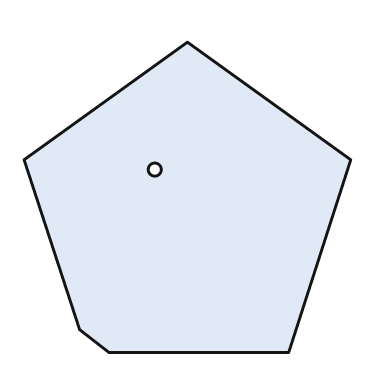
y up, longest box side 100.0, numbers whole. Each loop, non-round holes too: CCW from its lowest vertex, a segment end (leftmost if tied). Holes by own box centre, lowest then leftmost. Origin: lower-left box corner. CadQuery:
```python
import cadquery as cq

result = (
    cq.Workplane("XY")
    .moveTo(26.0, 0.0)
    .lineTo(81.0, 0.0)
    .lineTo(100.0, 59.0)
    .lineTo(50.0, 95.0)
    .lineTo(0.0, 59.0)
    .lineTo(17.0, 7.0)
    .close()
    .moveTo(40.0, 56.0)
    .circle(2.0)
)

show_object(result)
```